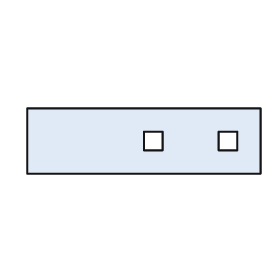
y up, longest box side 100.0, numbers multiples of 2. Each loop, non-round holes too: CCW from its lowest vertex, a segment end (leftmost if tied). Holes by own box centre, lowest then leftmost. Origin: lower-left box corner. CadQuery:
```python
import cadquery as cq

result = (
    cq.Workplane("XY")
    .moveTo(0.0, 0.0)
    .lineTo(100.0, 0.0)
    .lineTo(100.0, 28.0)
    .lineTo(0.0, 28.0)
    .close()
    .moveTo(50.0, 10.0)
    .lineTo(58.0, 10.0)
    .lineTo(58.0, 18.0)
    .lineTo(50.0, 18.0)
    .close()
    .moveTo(82.0, 10.0)
    .lineTo(90.0, 10.0)
    .lineTo(90.0, 18.0)
    .lineTo(82.0, 18.0)
    .close()
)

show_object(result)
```